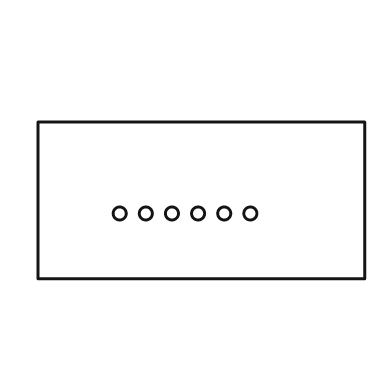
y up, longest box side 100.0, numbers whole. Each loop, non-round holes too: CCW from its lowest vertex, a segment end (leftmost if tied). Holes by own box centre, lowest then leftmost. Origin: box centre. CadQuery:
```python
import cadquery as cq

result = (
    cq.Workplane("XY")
    .moveTo(-50.0, -24.0)
    .lineTo(50.0, -24.0)
    .lineTo(50.0, 24.0)
    .lineTo(-50.0, 24.0)
    .close()
    .moveTo(-25.0, -4.0)
    .circle(2.0)
    .moveTo(-17.0, -4.0)
    .circle(2.0)
    .moveTo(-9.0, -4.0)
    .circle(2.0)
    .moveTo(-1.0, -4.0)
    .circle(2.0)
    .moveTo(7.0, -4.0)
    .circle(2.0)
    .moveTo(15.0, -4.0)
    .circle(2.0)
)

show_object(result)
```